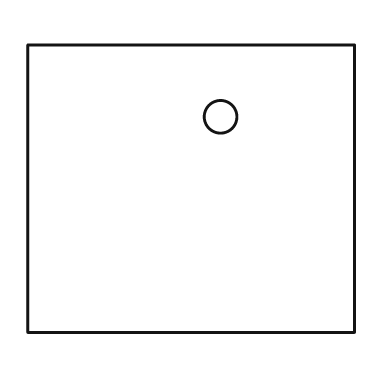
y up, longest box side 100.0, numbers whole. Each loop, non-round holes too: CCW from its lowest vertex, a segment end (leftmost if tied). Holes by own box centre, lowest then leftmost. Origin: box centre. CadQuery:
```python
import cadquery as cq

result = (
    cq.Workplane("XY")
    .moveTo(-50.0, -44.0)
    .lineTo(50.0, -44.0)
    .lineTo(50.0, 44.0)
    .lineTo(-50.0, 44.0)
    .close()
    .moveTo(9.0, 22.0)
    .circle(5.0)
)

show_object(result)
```